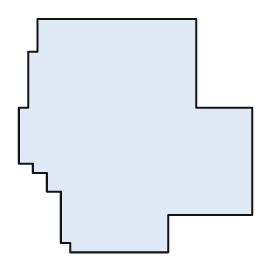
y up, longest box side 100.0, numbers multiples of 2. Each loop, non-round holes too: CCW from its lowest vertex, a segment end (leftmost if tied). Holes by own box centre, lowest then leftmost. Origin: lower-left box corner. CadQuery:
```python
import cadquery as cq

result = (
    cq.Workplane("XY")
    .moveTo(22.0, 0.0)
    .lineTo(64.0, 0.0)
    .lineTo(64.0, 16.0)
    .lineTo(100.0, 16.0)
    .lineTo(100.0, 62.0)
    .lineTo(76.0, 62.0)
    .lineTo(76.0, 100.0)
    .lineTo(8.0, 100.0)
    .lineTo(8.0, 86.0)
    .lineTo(4.0, 86.0)
    .lineTo(4.0, 62.0)
    .lineTo(0.0, 62.0)
    .lineTo(0.0, 38.0)
    .lineTo(6.0, 38.0)
    .lineTo(6.0, 34.0)
    .lineTo(12.0, 34.0)
    .lineTo(12.0, 26.0)
    .lineTo(18.0, 26.0)
    .lineTo(18.0, 4.0)
    .lineTo(22.0, 4.0)
    .close()
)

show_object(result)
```